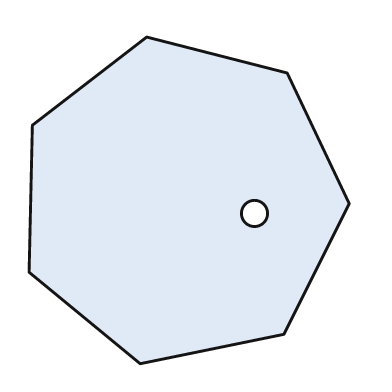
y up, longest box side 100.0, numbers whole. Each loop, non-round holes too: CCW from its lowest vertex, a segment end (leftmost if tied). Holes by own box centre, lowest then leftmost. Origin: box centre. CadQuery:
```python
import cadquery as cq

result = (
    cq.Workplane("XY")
    .moveTo(-15.0, -50.0)
    .lineTo(29.0, -41.0)
    .lineTo(49.0, -1.0)
    .lineTo(30.0, 39.0)
    .lineTo(-13.0, 50.0)
    .lineTo(-48.0, 23.0)
    .lineTo(-49.0, -22.0)
    .close()
    .moveTo(20.0, -4.0)
    .circle(4.0)
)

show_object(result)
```